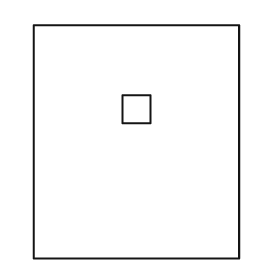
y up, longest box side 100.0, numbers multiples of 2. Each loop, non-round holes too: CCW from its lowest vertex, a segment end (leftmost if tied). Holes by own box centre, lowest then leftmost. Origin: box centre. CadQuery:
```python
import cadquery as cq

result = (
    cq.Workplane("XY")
    .moveTo(-44.0, -50.0)
    .lineTo(44.0, -50.0)
    .lineTo(44.0, 50.0)
    .lineTo(-44.0, 50.0)
    .close()
    .moveTo(-6.0, 8.0)
    .lineTo(6.0, 8.0)
    .lineTo(6.0, 20.0)
    .lineTo(-6.0, 20.0)
    .close()
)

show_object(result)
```